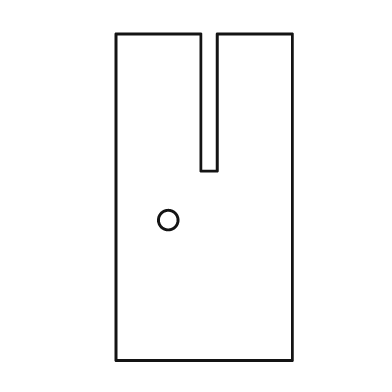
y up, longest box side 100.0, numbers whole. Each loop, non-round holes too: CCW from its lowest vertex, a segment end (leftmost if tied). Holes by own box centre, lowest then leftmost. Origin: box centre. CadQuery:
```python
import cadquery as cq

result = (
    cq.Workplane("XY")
    .moveTo(-27.0, -50.0)
    .lineTo(27.0, -50.0)
    .lineTo(27.0, 50.0)
    .lineTo(4.0, 50.0)
    .lineTo(4.0, 8.0)
    .lineTo(-1.0, 8.0)
    .lineTo(-1.0, 50.0)
    .lineTo(-27.0, 50.0)
    .close()
    .moveTo(-11.0, -7.0)
    .circle(3.0)
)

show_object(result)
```